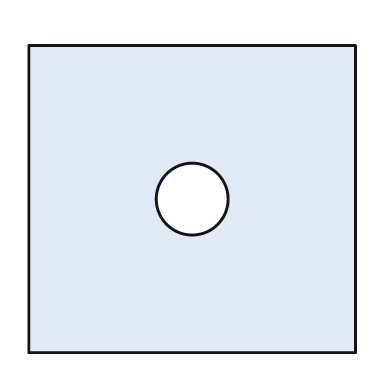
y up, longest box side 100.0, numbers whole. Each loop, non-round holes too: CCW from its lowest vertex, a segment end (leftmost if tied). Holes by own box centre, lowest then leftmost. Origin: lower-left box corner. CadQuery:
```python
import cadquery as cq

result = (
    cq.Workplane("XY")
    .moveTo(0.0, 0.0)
    .lineTo(100.0, 0.0)
    .lineTo(100.0, 94.0)
    .lineTo(0.0, 94.0)
    .close()
    .moveTo(50.0, 47.0)
    .circle(11.0)
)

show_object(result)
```